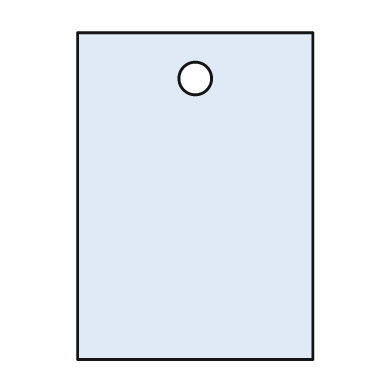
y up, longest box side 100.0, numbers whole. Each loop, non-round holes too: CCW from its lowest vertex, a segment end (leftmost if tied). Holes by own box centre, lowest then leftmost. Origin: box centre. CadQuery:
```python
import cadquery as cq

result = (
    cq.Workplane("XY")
    .moveTo(-36.0, -50.0)
    .lineTo(36.0, -50.0)
    .lineTo(36.0, 50.0)
    .lineTo(-36.0, 50.0)
    .close()
    .moveTo(0.0, 36.0)
    .circle(5.0)
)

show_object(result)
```